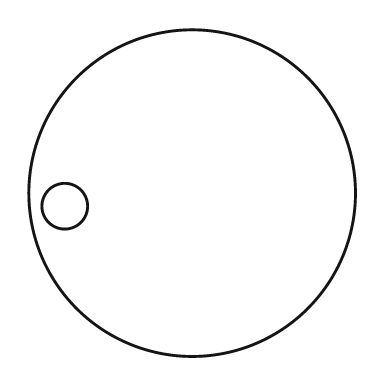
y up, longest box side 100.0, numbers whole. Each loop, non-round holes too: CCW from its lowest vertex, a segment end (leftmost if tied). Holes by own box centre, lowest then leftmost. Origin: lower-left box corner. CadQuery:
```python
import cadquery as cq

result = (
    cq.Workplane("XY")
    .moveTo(50.0, 50.0)
    .circle(50.0)
    .moveTo(11.0, 46.0)
    .circle(7.0)
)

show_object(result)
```